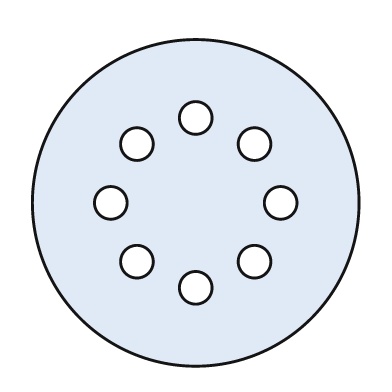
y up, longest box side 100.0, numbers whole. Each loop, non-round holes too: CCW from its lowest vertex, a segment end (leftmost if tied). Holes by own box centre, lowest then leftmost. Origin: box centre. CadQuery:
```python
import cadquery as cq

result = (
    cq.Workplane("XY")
    .moveTo(0.0, 0.0)
    .circle(50.0)
    .moveTo(0.0, -26.0)
    .circle(5.0)
    .moveTo(-18.0, -18.0)
    .circle(5.0)
    .moveTo(18.0, -18.0)
    .circle(5.0)
    .moveTo(-26.0, 0.0)
    .circle(5.0)
    .moveTo(26.0, 0.0)
    .circle(5.0)
    .moveTo(-18.0, 18.0)
    .circle(5.0)
    .moveTo(18.0, 18.0)
    .circle(5.0)
    .moveTo(0.0, 26.0)
    .circle(5.0)
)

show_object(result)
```